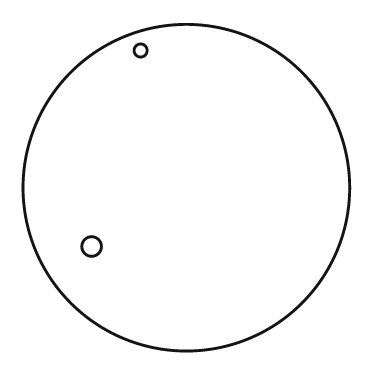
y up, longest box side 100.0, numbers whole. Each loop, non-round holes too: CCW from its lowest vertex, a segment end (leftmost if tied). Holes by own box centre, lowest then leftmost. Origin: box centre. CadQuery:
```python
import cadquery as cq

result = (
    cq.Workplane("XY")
    .moveTo(0.0, 0.0)
    .circle(50.0)
    .moveTo(-29.0, -18.0)
    .circle(3.0)
    .moveTo(-14.0, 42.0)
    .circle(2.0)
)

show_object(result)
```